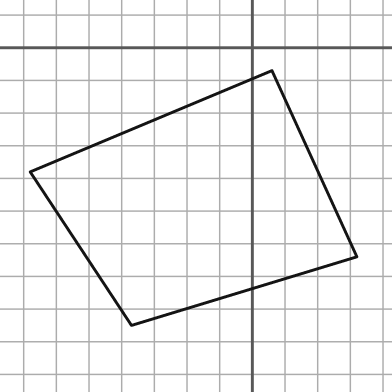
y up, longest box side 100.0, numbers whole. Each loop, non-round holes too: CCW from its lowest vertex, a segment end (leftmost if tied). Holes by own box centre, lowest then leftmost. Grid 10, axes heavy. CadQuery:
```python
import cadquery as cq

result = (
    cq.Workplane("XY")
    .moveTo(-37.0, -85.0)
    .lineTo(32.0, -64.0)
    .lineTo(6.0, -7.0)
    .lineTo(-68.0, -38.0)
    .close()
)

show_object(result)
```